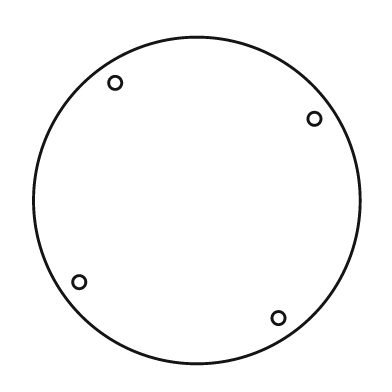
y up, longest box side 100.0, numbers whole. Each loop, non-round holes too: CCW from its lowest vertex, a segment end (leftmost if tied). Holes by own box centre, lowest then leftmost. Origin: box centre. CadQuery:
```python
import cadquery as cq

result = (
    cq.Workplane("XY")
    .moveTo(0.0, 0.0)
    .circle(50.0)
    .moveTo(25.0, -36.0)
    .circle(2.0)
    .moveTo(-36.0, -25.0)
    .circle(2.0)
    .moveTo(36.0, 25.0)
    .circle(2.0)
    .moveTo(-25.0, 36.0)
    .circle(2.0)
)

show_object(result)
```